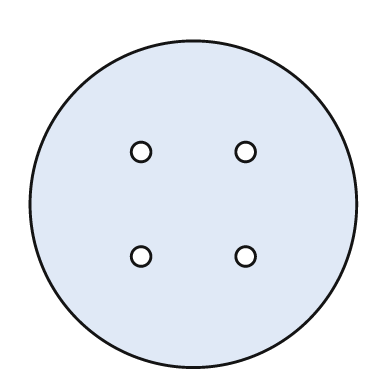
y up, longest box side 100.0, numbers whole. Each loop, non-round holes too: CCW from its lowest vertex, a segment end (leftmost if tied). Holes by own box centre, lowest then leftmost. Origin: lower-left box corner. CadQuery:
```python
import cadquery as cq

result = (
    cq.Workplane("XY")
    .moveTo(50.0, 50.0)
    .circle(50.0)
    .moveTo(34.0, 34.0)
    .circle(3.0)
    .moveTo(66.0, 34.0)
    .circle(3.0)
    .moveTo(34.0, 66.0)
    .circle(3.0)
    .moveTo(66.0, 66.0)
    .circle(3.0)
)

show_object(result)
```